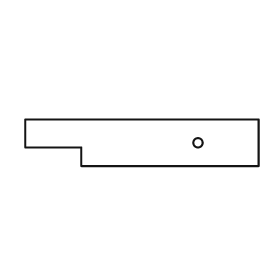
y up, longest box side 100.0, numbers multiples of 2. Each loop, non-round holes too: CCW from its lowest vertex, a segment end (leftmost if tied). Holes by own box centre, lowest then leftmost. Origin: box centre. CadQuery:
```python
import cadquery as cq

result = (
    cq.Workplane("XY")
    .moveTo(-26.0, -10.0)
    .lineTo(50.0, -10.0)
    .lineTo(50.0, 10.0)
    .lineTo(-50.0, 10.0)
    .lineTo(-50.0, -2.0)
    .lineTo(-26.0, -2.0)
    .close()
    .moveTo(24.0, 0.0)
    .circle(2.0)
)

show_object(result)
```